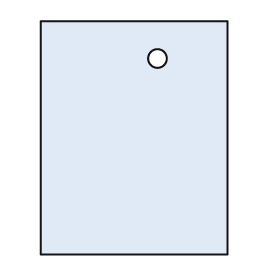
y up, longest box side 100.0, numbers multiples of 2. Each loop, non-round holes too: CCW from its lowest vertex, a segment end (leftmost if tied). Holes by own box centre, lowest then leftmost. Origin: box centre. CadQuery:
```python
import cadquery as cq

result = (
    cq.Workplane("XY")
    .moveTo(-40.0, -50.0)
    .lineTo(40.0, -50.0)
    .lineTo(40.0, 50.0)
    .lineTo(-40.0, 50.0)
    .close()
    .moveTo(10.0, 34.0)
    .circle(4.0)
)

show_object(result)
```